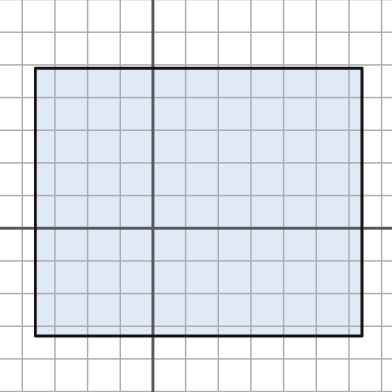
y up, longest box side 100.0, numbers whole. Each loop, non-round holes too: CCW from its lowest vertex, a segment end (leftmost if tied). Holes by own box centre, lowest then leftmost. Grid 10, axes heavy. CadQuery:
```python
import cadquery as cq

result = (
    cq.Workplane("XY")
    .moveTo(-36.0, -33.0)
    .lineTo(64.0, -33.0)
    .lineTo(64.0, 49.0)
    .lineTo(-36.0, 49.0)
    .close()
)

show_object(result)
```